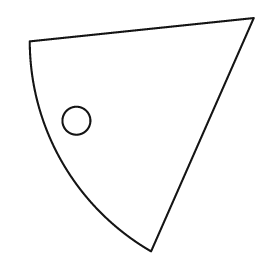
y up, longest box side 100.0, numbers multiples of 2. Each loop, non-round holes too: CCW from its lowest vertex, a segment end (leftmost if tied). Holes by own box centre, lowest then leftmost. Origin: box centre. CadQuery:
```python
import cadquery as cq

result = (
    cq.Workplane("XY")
    .moveTo(4.0, -50.0)
    .lineTo(48.0, 50.0)
    .lineTo(-48.0, 40.0)
    .threePointArc((-34.0, -12.0), (4.0, -50.0))
    .close()
    .moveTo(-28.0, 6.0)
    .circle(6.0)
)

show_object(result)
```